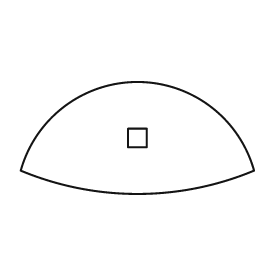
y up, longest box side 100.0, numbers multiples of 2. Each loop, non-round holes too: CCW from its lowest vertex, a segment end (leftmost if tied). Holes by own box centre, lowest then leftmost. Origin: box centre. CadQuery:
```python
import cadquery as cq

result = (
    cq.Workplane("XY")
    .moveTo(-50.0, -14.0)
    .threePointArc((0.0, -24.0), (50.0, -14.0))
    .threePointArc((0.0, 24.0), (-50.0, -14.0))
    .close()
    .moveTo(-4.0, -4.0)
    .lineTo(4.0, -4.0)
    .lineTo(4.0, 4.0)
    .lineTo(-4.0, 4.0)
    .close()
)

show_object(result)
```